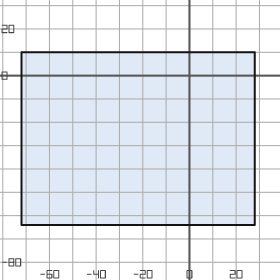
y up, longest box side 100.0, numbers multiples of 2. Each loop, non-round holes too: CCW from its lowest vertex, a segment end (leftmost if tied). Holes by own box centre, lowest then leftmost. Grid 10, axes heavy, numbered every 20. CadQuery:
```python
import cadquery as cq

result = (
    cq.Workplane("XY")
    .moveTo(-72.0, -64.0)
    .lineTo(28.0, -64.0)
    .lineTo(28.0, 10.0)
    .lineTo(-72.0, 10.0)
    .close()
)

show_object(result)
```